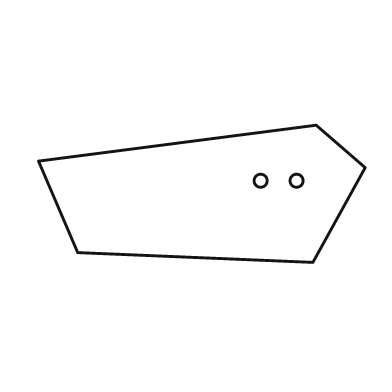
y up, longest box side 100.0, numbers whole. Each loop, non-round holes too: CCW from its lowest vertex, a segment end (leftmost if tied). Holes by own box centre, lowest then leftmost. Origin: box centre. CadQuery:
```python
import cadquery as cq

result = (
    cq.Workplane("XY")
    .moveTo(34.0, -21.0)
    .lineTo(50.0, 8.0)
    .lineTo(35.0, 21.0)
    .lineTo(-50.0, 10.0)
    .lineTo(-38.0, -18.0)
    .close()
    .moveTo(18.0, 4.0)
    .circle(2.0)
    .moveTo(29.0, 4.0)
    .circle(2.0)
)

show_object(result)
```